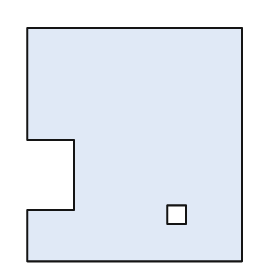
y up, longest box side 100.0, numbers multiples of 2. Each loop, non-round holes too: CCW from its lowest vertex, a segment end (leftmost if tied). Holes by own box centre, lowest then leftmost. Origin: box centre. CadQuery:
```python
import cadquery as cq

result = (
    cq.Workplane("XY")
    .moveTo(-46.0, -50.0)
    .lineTo(46.0, -50.0)
    .lineTo(46.0, 50.0)
    .lineTo(-46.0, 50.0)
    .lineTo(-46.0, 2.0)
    .lineTo(-26.0, 2.0)
    .lineTo(-26.0, -28.0)
    .lineTo(-46.0, -28.0)
    .close()
    .moveTo(14.0, -34.0)
    .lineTo(22.0, -34.0)
    .lineTo(22.0, -26.0)
    .lineTo(14.0, -26.0)
    .close()
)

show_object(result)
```